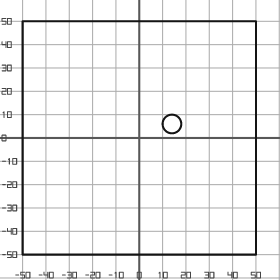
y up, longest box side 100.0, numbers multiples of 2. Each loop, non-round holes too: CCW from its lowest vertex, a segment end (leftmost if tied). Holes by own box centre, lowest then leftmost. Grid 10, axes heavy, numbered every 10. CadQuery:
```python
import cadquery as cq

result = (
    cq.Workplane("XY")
    .moveTo(-50.0, -50.0)
    .lineTo(50.0, -50.0)
    .lineTo(50.0, 50.0)
    .lineTo(-50.0, 50.0)
    .close()
    .moveTo(14.0, 6.0)
    .circle(4.0)
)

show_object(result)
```